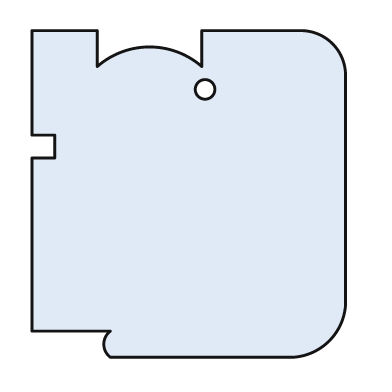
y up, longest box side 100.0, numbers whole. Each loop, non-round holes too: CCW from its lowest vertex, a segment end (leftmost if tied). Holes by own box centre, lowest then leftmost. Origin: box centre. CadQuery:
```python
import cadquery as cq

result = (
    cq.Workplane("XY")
    .moveTo(-24.0, -50.0)
    .lineTo(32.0, -50.0)
    .threePointArc((43.0, -45.0), (48.0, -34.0))
    .lineTo(48.0, 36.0)
    .threePointArc((44.0, 46.0), (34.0, 50.0))
    .lineTo(4.0, 50.0)
    .lineTo(4.0, 39.0)
    .threePointArc((-12.0, 45.0), (-28.0, 39.0))
    .lineTo(-28.0, 50.0)
    .lineTo(-48.0, 50.0)
    .lineTo(-48.0, 18.0)
    .lineTo(-41.0, 18.0)
    .lineTo(-41.0, 11.0)
    .lineTo(-48.0, 11.0)
    .lineTo(-48.0, -42.0)
    .lineTo(-24.0, -42.0)
    .threePointArc((-26.0, -46.0), (-24.0, -50.0))
    .close()
    .moveTo(5.0, 32.0)
    .circle(3.0)
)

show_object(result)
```